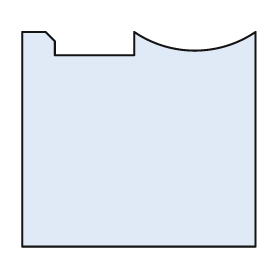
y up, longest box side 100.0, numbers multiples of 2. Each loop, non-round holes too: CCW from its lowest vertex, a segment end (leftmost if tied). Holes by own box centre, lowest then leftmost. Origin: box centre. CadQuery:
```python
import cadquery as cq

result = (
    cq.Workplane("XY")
    .moveTo(-50.0, -46.0)
    .lineTo(50.0, -46.0)
    .lineTo(50.0, 46.0)
    .threePointArc((24.0, 38.0), (-2.0, 46.0))
    .lineTo(-2.0, 36.0)
    .lineTo(-36.0, 36.0)
    .lineTo(-36.0, 42.0)
    .lineTo(-40.0, 46.0)
    .lineTo(-50.0, 46.0)
    .close()
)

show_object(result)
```